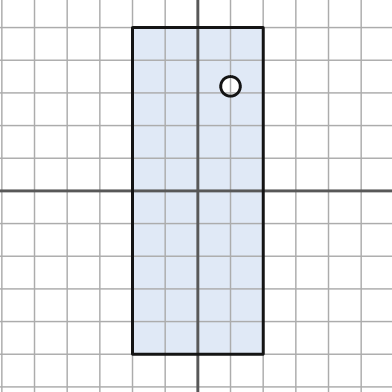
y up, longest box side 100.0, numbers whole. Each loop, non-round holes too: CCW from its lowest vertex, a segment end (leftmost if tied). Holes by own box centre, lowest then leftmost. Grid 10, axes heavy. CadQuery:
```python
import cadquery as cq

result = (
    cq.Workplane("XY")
    .moveTo(-20.0, -50.0)
    .lineTo(20.0, -50.0)
    .lineTo(20.0, 50.0)
    .lineTo(-20.0, 50.0)
    .close()
    .moveTo(10.0, 32.0)
    .circle(3.0)
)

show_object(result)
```